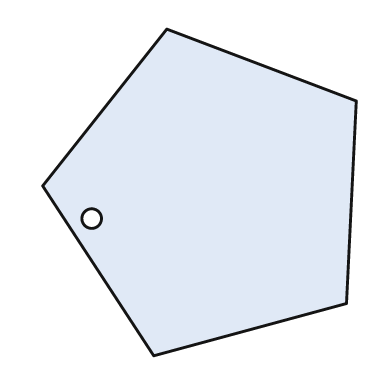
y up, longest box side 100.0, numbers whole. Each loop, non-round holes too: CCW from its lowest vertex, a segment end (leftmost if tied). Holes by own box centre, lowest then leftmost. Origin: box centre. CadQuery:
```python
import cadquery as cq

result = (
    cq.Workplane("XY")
    .moveTo(-14.0, -50.0)
    .lineTo(45.0, -34.0)
    .lineTo(48.0, 28.0)
    .lineTo(-10.0, 50.0)
    .lineTo(-48.0, 2.0)
    .close()
    .moveTo(-33.0, -8.0)
    .circle(3.0)
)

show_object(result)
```